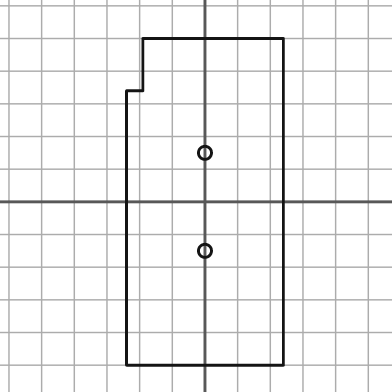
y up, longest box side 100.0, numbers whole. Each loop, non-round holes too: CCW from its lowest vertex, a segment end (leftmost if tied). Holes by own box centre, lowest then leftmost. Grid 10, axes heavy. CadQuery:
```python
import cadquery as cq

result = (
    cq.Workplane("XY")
    .moveTo(-24.0, -50.0)
    .lineTo(24.0, -50.0)
    .lineTo(24.0, 50.0)
    .lineTo(-19.0, 50.0)
    .lineTo(-19.0, 34.0)
    .lineTo(-24.0, 34.0)
    .close()
    .moveTo(0.0, -15.0)
    .circle(2.0)
    .moveTo(0.0, 15.0)
    .circle(2.0)
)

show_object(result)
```